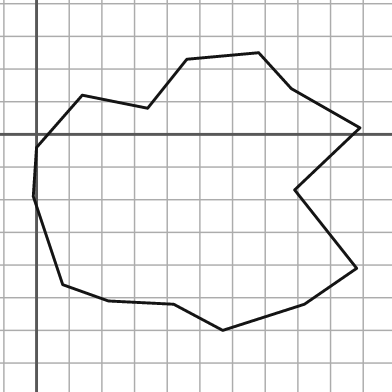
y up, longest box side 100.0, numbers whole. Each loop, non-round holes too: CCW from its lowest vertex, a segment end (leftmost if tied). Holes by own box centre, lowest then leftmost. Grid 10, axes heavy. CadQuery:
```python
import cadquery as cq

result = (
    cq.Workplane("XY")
    .moveTo(57.0, -60.0)
    .lineTo(82.0, -52.0)
    .lineTo(98.0, -41.0)
    .lineTo(79.0, -17.0)
    .lineTo(99.0, 2.0)
    .lineTo(78.0, 14.0)
    .lineTo(68.0, 25.0)
    .lineTo(46.0, 23.0)
    .lineTo(34.0, 8.0)
    .lineTo(14.0, 12.0)
    .lineTo(0.0, -4.0)
    .lineTo(-1.0, -19.0)
    .lineTo(8.0, -46.0)
    .lineTo(22.0, -51.0)
    .lineTo(42.0, -52.0)
    .close()
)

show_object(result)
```